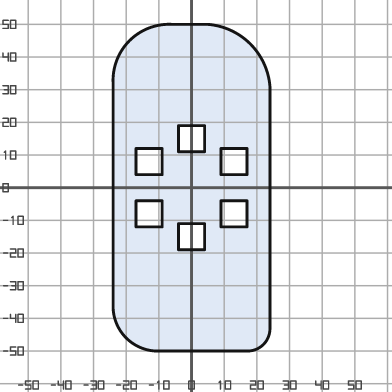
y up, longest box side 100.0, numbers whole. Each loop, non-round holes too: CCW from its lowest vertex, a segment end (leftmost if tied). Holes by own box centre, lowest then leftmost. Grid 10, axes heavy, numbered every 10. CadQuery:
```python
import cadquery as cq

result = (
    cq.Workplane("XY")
    .moveTo(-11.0, -50.0)
    .lineTo(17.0, -50.0)
    .threePointArc((22.0, -48.0), (24.0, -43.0))
    .lineTo(24.0, 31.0)
    .threePointArc((18.0, 44.0), (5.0, 50.0))
    .lineTo(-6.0, 50.0)
    .threePointArc((-19.0, 45.0), (-24.0, 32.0))
    .lineTo(-24.0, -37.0)
    .threePointArc((-20.0, -46.0), (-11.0, -50.0))
    .close()
    .moveTo(-4.0, -19.0)
    .lineTo(4.0, -19.0)
    .lineTo(4.0, -11.0)
    .lineTo(-4.0, -11.0)
    .close()
    .moveTo(-17.0, -12.0)
    .lineTo(-9.0, -12.0)
    .lineTo(-9.0, -4.0)
    .lineTo(-17.0, -4.0)
    .close()
    .moveTo(9.0, -12.0)
    .lineTo(17.0, -12.0)
    .lineTo(17.0, -4.0)
    .lineTo(9.0, -4.0)
    .close()
    .moveTo(-17.0, 4.0)
    .lineTo(-9.0, 4.0)
    .lineTo(-9.0, 12.0)
    .lineTo(-17.0, 12.0)
    .close()
    .moveTo(9.0, 4.0)
    .lineTo(17.0, 4.0)
    .lineTo(17.0, 12.0)
    .lineTo(9.0, 12.0)
    .close()
    .moveTo(-4.0, 11.0)
    .lineTo(4.0, 11.0)
    .lineTo(4.0, 19.0)
    .lineTo(-4.0, 19.0)
    .close()
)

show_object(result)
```